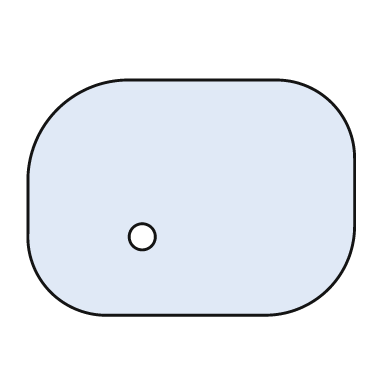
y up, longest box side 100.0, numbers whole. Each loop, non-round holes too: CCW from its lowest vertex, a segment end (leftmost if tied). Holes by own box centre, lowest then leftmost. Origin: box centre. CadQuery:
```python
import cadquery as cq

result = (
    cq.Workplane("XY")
    .moveTo(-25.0, -36.0)
    .lineTo(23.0, -36.0)
    .threePointArc((42.0, -28.0), (50.0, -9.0))
    .lineTo(50.0, 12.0)
    .threePointArc((43.0, 29.0), (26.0, 36.0))
    .lineTo(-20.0, 36.0)
    .threePointArc((-41.0, 27.0), (-50.0, 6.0))
    .lineTo(-50.0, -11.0)
    .threePointArc((-43.0, -29.0), (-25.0, -36.0))
    .close()
    .moveTo(-15.0, -12.0)
    .circle(4.0)
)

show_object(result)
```